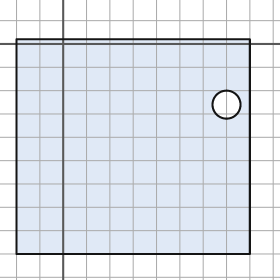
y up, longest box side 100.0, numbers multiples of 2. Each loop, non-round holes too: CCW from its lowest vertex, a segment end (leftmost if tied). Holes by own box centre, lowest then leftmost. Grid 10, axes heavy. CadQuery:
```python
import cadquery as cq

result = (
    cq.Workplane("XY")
    .moveTo(-20.0, -90.0)
    .lineTo(80.0, -90.0)
    .lineTo(80.0, 2.0)
    .lineTo(-20.0, 2.0)
    .close()
    .moveTo(70.0, -26.0)
    .circle(6.0)
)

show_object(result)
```